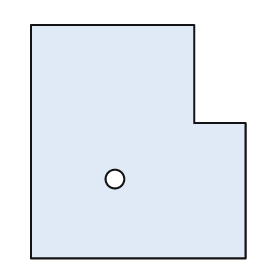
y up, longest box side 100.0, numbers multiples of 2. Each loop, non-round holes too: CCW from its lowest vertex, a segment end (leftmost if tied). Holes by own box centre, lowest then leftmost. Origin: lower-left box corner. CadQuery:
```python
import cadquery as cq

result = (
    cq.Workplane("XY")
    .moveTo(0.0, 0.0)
    .lineTo(92.0, 0.0)
    .lineTo(92.0, 58.0)
    .lineTo(70.0, 58.0)
    .lineTo(70.0, 100.0)
    .lineTo(0.0, 100.0)
    .close()
    .moveTo(36.0, 34.0)
    .circle(4.0)
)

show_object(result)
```